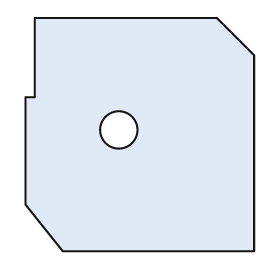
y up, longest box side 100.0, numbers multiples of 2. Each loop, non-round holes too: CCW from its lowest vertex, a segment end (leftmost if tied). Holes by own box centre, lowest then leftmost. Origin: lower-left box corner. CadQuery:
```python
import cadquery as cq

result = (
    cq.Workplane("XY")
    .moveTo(16.0, 0.0)
    .lineTo(98.0, 0.0)
    .lineTo(98.0, 84.0)
    .lineTo(82.0, 100.0)
    .lineTo(4.0, 100.0)
    .lineTo(4.0, 66.0)
    .lineTo(0.0, 66.0)
    .lineTo(0.0, 20.0)
    .close()
    .moveTo(40.0, 52.0)
    .circle(8.0)
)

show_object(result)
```